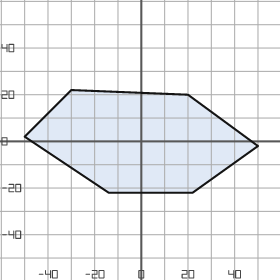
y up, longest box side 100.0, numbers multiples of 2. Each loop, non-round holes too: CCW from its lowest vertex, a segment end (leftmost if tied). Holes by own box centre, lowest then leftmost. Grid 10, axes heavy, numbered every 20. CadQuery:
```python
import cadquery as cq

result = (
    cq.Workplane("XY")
    .moveTo(-14.0, -22.0)
    .lineTo(22.0, -22.0)
    .lineTo(50.0, -2.0)
    .lineTo(20.0, 20.0)
    .lineTo(-30.0, 22.0)
    .lineTo(-50.0, 2.0)
    .close()
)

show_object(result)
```